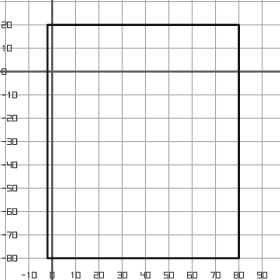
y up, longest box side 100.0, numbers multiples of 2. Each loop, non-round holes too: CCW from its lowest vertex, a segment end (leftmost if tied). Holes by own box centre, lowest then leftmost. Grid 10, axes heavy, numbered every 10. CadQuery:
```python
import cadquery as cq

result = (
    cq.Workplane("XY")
    .moveTo(-2.0, -80.0)
    .lineTo(80.0, -80.0)
    .lineTo(80.0, 20.0)
    .lineTo(-2.0, 20.0)
    .close()
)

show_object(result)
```